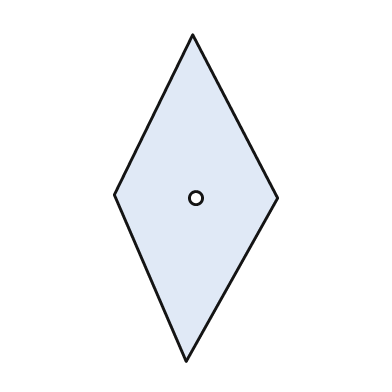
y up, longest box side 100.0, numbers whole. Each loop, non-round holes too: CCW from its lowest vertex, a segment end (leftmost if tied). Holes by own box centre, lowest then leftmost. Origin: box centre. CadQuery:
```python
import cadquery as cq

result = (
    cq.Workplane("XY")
    .moveTo(-3.0, -50.0)
    .lineTo(25.0, 0.0)
    .lineTo(-1.0, 50.0)
    .lineTo(-25.0, 1.0)
    .close()
    .moveTo(0.0, 0.0)
    .circle(2.0)
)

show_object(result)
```